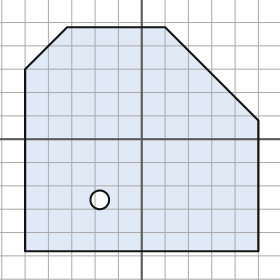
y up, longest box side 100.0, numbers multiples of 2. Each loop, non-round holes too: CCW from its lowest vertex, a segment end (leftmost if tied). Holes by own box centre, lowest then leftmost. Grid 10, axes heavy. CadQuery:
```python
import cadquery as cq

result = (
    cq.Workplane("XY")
    .moveTo(-50.0, -48.0)
    .lineTo(50.0, -48.0)
    .lineTo(50.0, 8.0)
    .lineTo(10.0, 48.0)
    .lineTo(-32.0, 48.0)
    .lineTo(-50.0, 30.0)
    .close()
    .moveTo(-18.0, -26.0)
    .circle(4.0)
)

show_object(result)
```